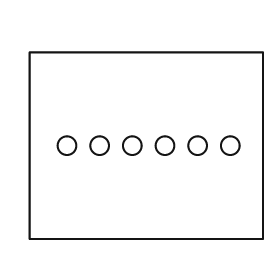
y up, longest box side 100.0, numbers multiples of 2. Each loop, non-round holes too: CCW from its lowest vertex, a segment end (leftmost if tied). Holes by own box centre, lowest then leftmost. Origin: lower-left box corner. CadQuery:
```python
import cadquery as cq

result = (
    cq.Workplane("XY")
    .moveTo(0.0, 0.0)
    .lineTo(100.0, 0.0)
    .lineTo(100.0, 80.0)
    .lineTo(0.0, 80.0)
    .close()
    .moveTo(16.0, 40.0)
    .circle(4.0)
    .moveTo(30.0, 40.0)
    .circle(4.0)
    .moveTo(44.0, 40.0)
    .circle(4.0)
    .moveTo(58.0, 40.0)
    .circle(4.0)
    .moveTo(72.0, 40.0)
    .circle(4.0)
    .moveTo(86.0, 40.0)
    .circle(4.0)
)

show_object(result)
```